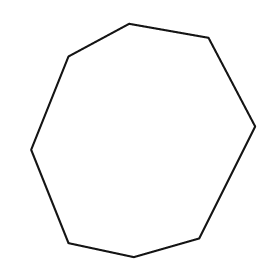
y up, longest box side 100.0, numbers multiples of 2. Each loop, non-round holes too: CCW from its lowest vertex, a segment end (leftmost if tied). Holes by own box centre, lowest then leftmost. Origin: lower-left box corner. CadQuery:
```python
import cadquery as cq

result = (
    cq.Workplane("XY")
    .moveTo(44.0, 0.0)
    .lineTo(72.0, 8.0)
    .lineTo(96.0, 56.0)
    .lineTo(76.0, 94.0)
    .lineTo(42.0, 100.0)
    .lineTo(16.0, 86.0)
    .lineTo(0.0, 46.0)
    .lineTo(16.0, 6.0)
    .close()
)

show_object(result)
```